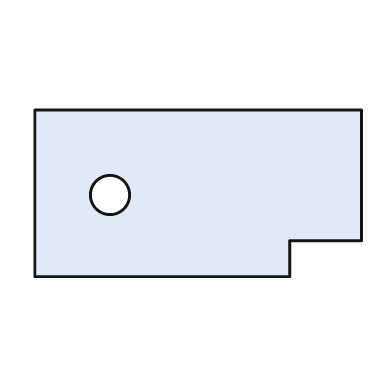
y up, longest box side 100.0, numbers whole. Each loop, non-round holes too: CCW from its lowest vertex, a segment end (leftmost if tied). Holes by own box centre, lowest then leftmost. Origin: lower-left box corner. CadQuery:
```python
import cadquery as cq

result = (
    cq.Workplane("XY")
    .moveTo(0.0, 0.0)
    .lineTo(78.0, 0.0)
    .lineTo(78.0, 11.0)
    .lineTo(100.0, 11.0)
    .lineTo(100.0, 51.0)
    .lineTo(0.0, 51.0)
    .close()
    .moveTo(23.0, 25.0)
    .circle(6.0)
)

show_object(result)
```